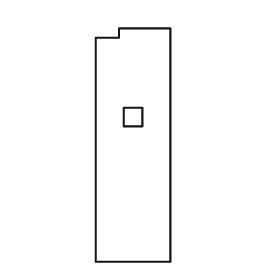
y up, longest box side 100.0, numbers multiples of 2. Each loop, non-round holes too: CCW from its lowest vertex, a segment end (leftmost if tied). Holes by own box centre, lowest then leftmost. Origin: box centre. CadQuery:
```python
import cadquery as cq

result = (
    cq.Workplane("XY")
    .moveTo(-16.0, -50.0)
    .lineTo(16.0, -50.0)
    .lineTo(16.0, 50.0)
    .lineTo(-6.0, 50.0)
    .lineTo(-6.0, 46.0)
    .lineTo(-16.0, 46.0)
    .close()
    .moveTo(-4.0, 8.0)
    .lineTo(4.0, 8.0)
    .lineTo(4.0, 16.0)
    .lineTo(-4.0, 16.0)
    .close()
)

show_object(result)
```